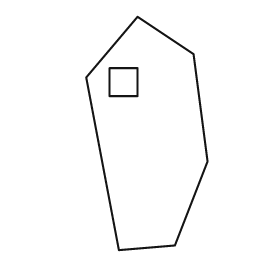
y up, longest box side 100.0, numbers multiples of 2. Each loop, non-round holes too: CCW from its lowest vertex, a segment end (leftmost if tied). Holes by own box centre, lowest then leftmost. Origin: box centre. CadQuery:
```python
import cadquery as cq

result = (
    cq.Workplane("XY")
    .moveTo(-12.0, -50.0)
    .lineTo(12.0, -48.0)
    .lineTo(26.0, -12.0)
    .lineTo(20.0, 34.0)
    .lineTo(-4.0, 50.0)
    .lineTo(-26.0, 24.0)
    .close()
    .moveTo(-16.0, 16.0)
    .lineTo(-4.0, 16.0)
    .lineTo(-4.0, 28.0)
    .lineTo(-16.0, 28.0)
    .close()
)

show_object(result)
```